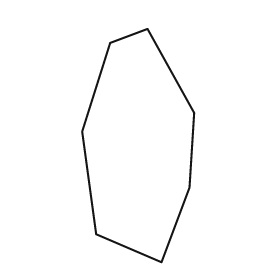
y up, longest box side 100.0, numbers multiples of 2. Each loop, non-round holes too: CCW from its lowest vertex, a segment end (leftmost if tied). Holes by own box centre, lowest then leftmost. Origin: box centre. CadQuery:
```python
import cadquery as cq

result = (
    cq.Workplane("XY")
    .moveTo(10.0, -50.0)
    .lineTo(22.0, -18.0)
    .lineTo(24.0, 14.0)
    .lineTo(4.0, 50.0)
    .lineTo(-12.0, 44.0)
    .lineTo(-24.0, 6.0)
    .lineTo(-18.0, -38.0)
    .close()
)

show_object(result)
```